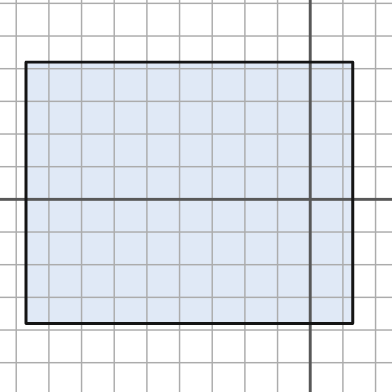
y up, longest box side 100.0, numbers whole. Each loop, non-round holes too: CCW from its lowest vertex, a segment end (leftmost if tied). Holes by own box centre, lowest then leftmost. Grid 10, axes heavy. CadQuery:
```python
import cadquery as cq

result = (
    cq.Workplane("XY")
    .moveTo(-87.0, -38.0)
    .lineTo(13.0, -38.0)
    .lineTo(13.0, 42.0)
    .lineTo(-87.0, 42.0)
    .close()
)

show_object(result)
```